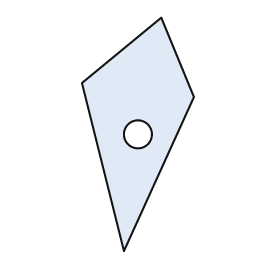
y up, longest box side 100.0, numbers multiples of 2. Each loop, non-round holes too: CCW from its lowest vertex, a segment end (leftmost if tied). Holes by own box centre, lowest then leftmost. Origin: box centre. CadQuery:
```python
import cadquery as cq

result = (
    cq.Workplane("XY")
    .moveTo(-6.0, -50.0)
    .lineTo(24.0, 16.0)
    .lineTo(10.0, 50.0)
    .lineTo(-24.0, 22.0)
    .close()
    .moveTo(0.0, 0.0)
    .circle(6.0)
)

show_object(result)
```